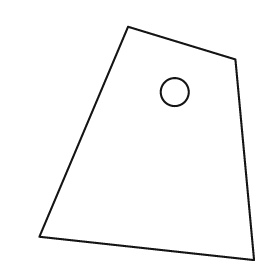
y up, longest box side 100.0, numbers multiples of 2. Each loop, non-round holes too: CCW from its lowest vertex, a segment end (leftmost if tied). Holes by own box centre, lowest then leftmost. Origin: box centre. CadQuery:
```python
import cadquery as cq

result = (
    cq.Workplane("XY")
    .moveTo(46.0, -50.0)
    .lineTo(38.0, 36.0)
    .lineTo(-8.0, 50.0)
    .lineTo(-46.0, -40.0)
    .close()
    .moveTo(12.0, 22.0)
    .circle(6.0)
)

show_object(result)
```